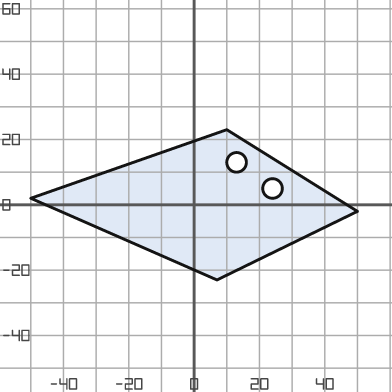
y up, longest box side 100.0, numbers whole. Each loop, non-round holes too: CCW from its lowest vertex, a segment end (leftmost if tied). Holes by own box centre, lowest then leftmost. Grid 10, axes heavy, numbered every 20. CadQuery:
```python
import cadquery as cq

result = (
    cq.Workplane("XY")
    .moveTo(7.0, -23.0)
    .lineTo(50.0, -2.0)
    .lineTo(10.0, 23.0)
    .lineTo(-50.0, 2.0)
    .close()
    .moveTo(24.0, 5.0)
    .circle(3.0)
    .moveTo(13.0, 13.0)
    .circle(3.0)
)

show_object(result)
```